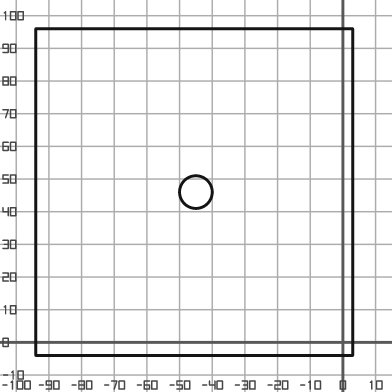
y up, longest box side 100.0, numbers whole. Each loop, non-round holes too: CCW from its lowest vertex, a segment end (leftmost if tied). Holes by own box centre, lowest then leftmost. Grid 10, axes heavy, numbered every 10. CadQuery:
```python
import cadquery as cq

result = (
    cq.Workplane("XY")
    .moveTo(-94.0, -4.0)
    .lineTo(3.0, -4.0)
    .lineTo(3.0, 96.0)
    .lineTo(-94.0, 96.0)
    .close()
    .moveTo(-45.0, 46.0)
    .circle(5.0)
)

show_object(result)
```